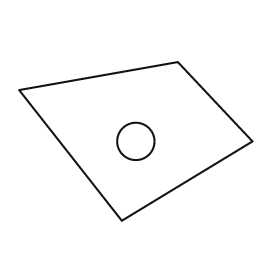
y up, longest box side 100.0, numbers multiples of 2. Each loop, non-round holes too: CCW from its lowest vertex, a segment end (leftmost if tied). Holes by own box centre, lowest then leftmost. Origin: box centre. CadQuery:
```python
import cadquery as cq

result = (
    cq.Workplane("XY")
    .moveTo(-6.0, -34.0)
    .lineTo(50.0, 0.0)
    .lineTo(18.0, 34.0)
    .lineTo(-50.0, 22.0)
    .close()
    .moveTo(0.0, 0.0)
    .circle(8.0)
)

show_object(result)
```